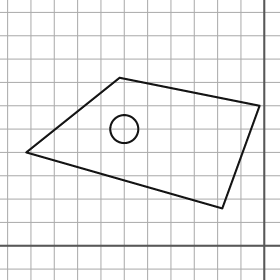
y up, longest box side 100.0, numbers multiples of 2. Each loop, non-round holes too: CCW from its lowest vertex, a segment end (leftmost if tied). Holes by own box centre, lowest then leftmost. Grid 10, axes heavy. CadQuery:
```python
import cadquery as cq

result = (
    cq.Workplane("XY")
    .moveTo(-18.0, 16.0)
    .lineTo(-2.0, 60.0)
    .lineTo(-62.0, 72.0)
    .lineTo(-102.0, 40.0)
    .close()
    .moveTo(-60.0, 50.0)
    .circle(6.0)
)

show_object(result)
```